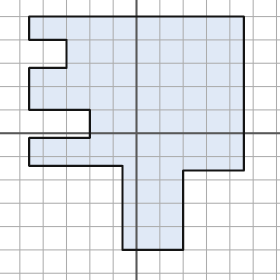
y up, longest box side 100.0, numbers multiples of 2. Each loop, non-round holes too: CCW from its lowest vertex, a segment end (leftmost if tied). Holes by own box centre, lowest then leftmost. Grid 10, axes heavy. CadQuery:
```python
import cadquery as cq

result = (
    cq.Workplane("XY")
    .moveTo(-6.0, -50.0)
    .lineTo(20.0, -50.0)
    .lineTo(20.0, -16.0)
    .lineTo(46.0, -16.0)
    .lineTo(46.0, 50.0)
    .lineTo(-46.0, 50.0)
    .lineTo(-46.0, 40.0)
    .lineTo(-30.0, 40.0)
    .lineTo(-30.0, 28.0)
    .lineTo(-46.0, 28.0)
    .lineTo(-46.0, 10.0)
    .lineTo(-20.0, 10.0)
    .lineTo(-20.0, -2.0)
    .lineTo(-46.0, -2.0)
    .lineTo(-46.0, -14.0)
    .lineTo(-6.0, -14.0)
    .close()
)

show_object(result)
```